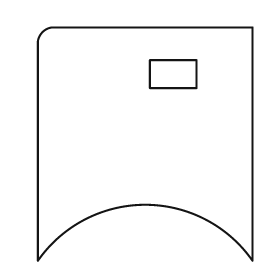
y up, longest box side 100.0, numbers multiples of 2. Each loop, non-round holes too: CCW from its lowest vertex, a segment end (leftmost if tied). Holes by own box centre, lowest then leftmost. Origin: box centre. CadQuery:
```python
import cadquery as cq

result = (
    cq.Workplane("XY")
    .moveTo(-46.0, -50.0)
    .threePointArc((0.0, -26.0), (46.0, -50.0))
    .lineTo(46.0, 50.0)
    .lineTo(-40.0, 50.0)
    .threePointArc((-44.0, 48.0), (-46.0, 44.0))
    .close()
    .moveTo(2.0, 24.0)
    .lineTo(22.0, 24.0)
    .lineTo(22.0, 36.0)
    .lineTo(2.0, 36.0)
    .close()
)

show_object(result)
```